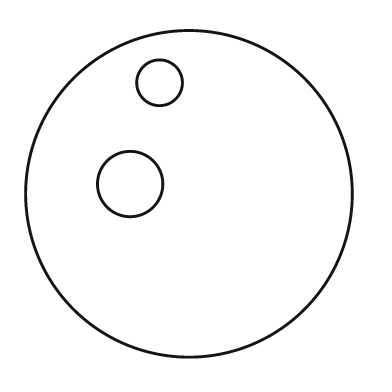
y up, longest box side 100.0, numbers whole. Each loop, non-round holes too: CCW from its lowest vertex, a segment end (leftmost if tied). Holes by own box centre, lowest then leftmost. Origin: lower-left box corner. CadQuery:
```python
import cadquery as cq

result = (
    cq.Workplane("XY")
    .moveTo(50.0, 50.0)
    .circle(50.0)
    .moveTo(32.0, 53.0)
    .circle(10.0)
    .moveTo(41.0, 84.0)
    .circle(7.0)
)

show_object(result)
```